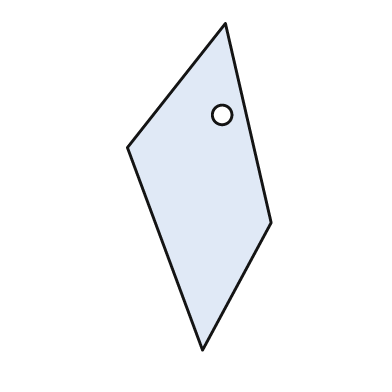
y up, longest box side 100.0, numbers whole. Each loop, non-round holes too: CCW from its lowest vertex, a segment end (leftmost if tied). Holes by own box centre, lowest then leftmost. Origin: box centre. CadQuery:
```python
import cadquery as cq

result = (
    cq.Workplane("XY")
    .moveTo(1.0, -50.0)
    .lineTo(22.0, -11.0)
    .lineTo(8.0, 50.0)
    .lineTo(-22.0, 12.0)
    .close()
    .moveTo(7.0, 22.0)
    .circle(3.0)
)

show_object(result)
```